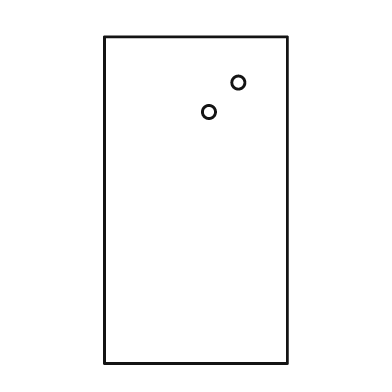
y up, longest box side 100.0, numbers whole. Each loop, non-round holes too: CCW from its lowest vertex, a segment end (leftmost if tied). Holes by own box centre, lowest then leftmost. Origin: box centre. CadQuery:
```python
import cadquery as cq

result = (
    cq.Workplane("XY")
    .moveTo(-28.0, -50.0)
    .lineTo(28.0, -50.0)
    .lineTo(28.0, 50.0)
    .lineTo(-28.0, 50.0)
    .close()
    .moveTo(4.0, 27.0)
    .circle(2.0)
    .moveTo(13.0, 36.0)
    .circle(2.0)
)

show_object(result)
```